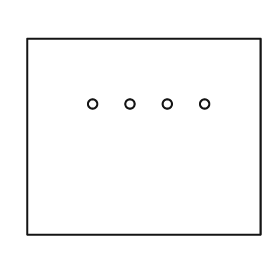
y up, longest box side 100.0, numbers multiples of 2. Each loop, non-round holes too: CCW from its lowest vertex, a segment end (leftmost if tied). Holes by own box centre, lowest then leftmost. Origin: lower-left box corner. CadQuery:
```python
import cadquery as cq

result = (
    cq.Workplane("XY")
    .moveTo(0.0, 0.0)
    .lineTo(100.0, 0.0)
    .lineTo(100.0, 84.0)
    .lineTo(0.0, 84.0)
    .close()
    .moveTo(28.0, 56.0)
    .circle(2.0)
    .moveTo(44.0, 56.0)
    .circle(2.0)
    .moveTo(60.0, 56.0)
    .circle(2.0)
    .moveTo(76.0, 56.0)
    .circle(2.0)
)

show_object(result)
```